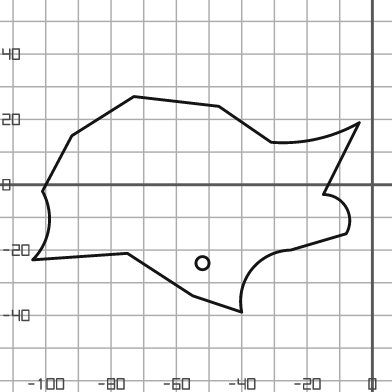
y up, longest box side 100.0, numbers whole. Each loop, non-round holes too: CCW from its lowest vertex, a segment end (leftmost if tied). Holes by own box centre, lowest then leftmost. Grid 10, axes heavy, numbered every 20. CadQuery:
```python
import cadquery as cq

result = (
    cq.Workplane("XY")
    .moveTo(-40.0, -39.0)
    .threePointArc((-37.0, -26.0), (-25.0, -20.0))
    .lineTo(-8.0, -15.0)
    .threePointArc((-8.0, -7.0), (-15.0, -3.0))
    .lineTo(-4.0, 19.0)
    .threePointArc((-17.0, 14.0), (-31.0, 13.0))
    .lineTo(-47.0, 24.0)
    .lineTo(-73.0, 27.0)
    .lineTo(-92.0, 15.0)
    .lineTo(-101.0, -2.0)
    .threePointArc((-99.0, -13.0), (-104.0, -23.0))
    .lineTo(-75.0, -21.0)
    .lineTo(-55.0, -34.0)
    .close()
    .moveTo(-52.0, -24.0)
    .circle(2.0)
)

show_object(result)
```